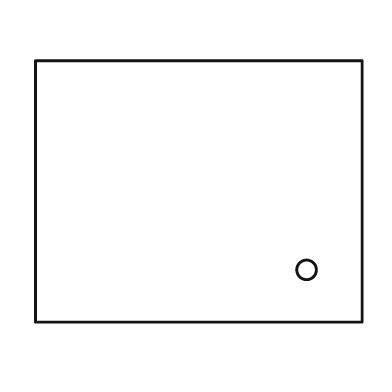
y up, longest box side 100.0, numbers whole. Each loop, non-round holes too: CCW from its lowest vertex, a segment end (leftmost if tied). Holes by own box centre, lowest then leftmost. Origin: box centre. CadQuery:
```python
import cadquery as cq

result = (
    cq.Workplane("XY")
    .moveTo(-50.0, -40.0)
    .lineTo(50.0, -40.0)
    .lineTo(50.0, 40.0)
    .lineTo(-50.0, 40.0)
    .close()
    .moveTo(33.0, -24.0)
    .circle(3.0)
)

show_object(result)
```